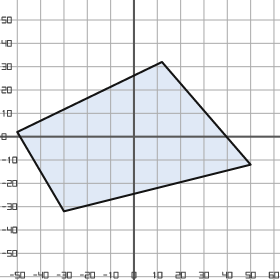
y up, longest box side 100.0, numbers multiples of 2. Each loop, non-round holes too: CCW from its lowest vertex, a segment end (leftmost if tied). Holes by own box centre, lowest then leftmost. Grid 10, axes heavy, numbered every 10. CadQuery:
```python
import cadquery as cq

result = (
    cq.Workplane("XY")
    .moveTo(-30.0, -32.0)
    .lineTo(50.0, -12.0)
    .lineTo(12.0, 32.0)
    .lineTo(-50.0, 2.0)
    .close()
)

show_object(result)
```